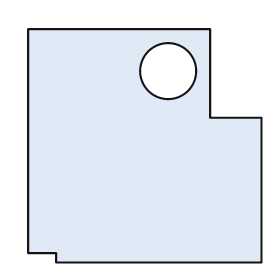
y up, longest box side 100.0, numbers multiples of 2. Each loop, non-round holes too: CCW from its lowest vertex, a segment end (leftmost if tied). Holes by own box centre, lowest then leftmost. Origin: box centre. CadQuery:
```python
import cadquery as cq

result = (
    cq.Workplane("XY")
    .moveTo(-38.0, -50.0)
    .lineTo(50.0, -50.0)
    .lineTo(50.0, 12.0)
    .lineTo(28.0, 12.0)
    .lineTo(28.0, 50.0)
    .lineTo(-50.0, 50.0)
    .lineTo(-50.0, -46.0)
    .lineTo(-38.0, -46.0)
    .close()
    .moveTo(10.0, 32.0)
    .circle(12.0)
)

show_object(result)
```